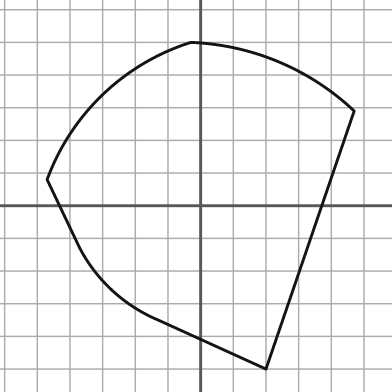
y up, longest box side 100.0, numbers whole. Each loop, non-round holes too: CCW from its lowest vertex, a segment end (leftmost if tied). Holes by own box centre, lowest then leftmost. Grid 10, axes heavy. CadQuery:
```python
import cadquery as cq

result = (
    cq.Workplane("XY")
    .moveTo(20.0, -50.0)
    .lineTo(47.0, 29.0)
    .threePointArc((24.0, 44.0), (-3.0, 50.0))
    .threePointArc((-30.0, 34.0), (-47.0, 8.0))
    .lineTo(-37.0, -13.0)
    .threePointArc((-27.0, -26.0), (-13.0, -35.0))
    .close()
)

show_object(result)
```